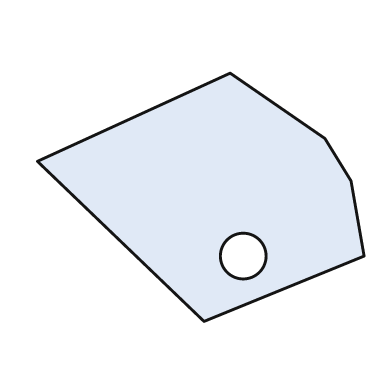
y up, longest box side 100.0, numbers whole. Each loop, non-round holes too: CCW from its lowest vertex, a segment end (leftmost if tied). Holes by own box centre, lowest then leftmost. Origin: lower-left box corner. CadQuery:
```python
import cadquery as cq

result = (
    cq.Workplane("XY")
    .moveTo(51.0, 0.0)
    .lineTo(100.0, 20.0)
    .lineTo(96.0, 43.0)
    .lineTo(88.0, 56.0)
    .lineTo(59.0, 76.0)
    .lineTo(0.0, 49.0)
    .close()
    .moveTo(63.0, 20.0)
    .circle(7.0)
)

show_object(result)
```